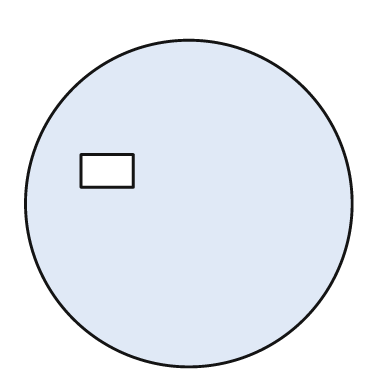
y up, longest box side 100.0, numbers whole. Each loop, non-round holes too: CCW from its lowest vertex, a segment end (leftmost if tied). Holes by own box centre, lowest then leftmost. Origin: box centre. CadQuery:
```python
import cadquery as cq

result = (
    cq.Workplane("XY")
    .moveTo(0.0, 0.0)
    .circle(50.0)
    .moveTo(-33.0, 5.0)
    .lineTo(-17.0, 5.0)
    .lineTo(-17.0, 15.0)
    .lineTo(-33.0, 15.0)
    .close()
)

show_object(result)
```